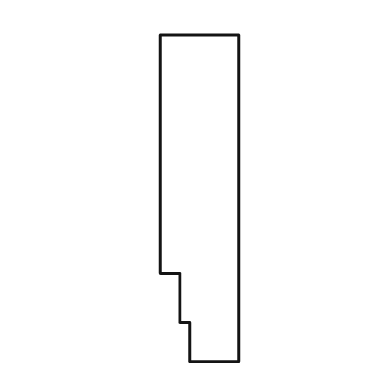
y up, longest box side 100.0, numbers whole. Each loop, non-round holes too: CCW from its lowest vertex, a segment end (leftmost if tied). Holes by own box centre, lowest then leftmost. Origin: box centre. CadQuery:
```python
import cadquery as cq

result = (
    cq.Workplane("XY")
    .moveTo(-3.0, -50.0)
    .lineTo(12.0, -50.0)
    .lineTo(12.0, 50.0)
    .lineTo(-12.0, 50.0)
    .lineTo(-12.0, -23.0)
    .lineTo(-6.0, -23.0)
    .lineTo(-6.0, -38.0)
    .lineTo(-3.0, -38.0)
    .close()
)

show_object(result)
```